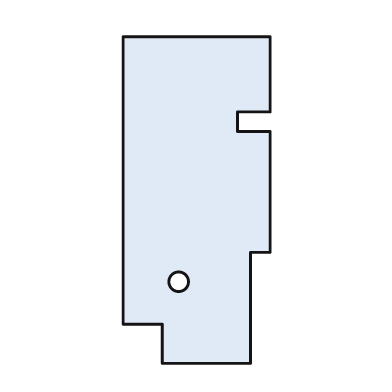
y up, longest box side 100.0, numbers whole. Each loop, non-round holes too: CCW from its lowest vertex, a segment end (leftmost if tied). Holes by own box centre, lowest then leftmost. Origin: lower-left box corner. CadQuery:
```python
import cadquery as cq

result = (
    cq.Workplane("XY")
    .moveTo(12.0, 0.0)
    .lineTo(39.0, 0.0)
    .lineTo(39.0, 34.0)
    .lineTo(45.0, 34.0)
    .lineTo(45.0, 71.0)
    .lineTo(35.0, 71.0)
    .lineTo(35.0, 77.0)
    .lineTo(45.0, 77.0)
    .lineTo(45.0, 100.0)
    .lineTo(0.0, 100.0)
    .lineTo(0.0, 12.0)
    .lineTo(12.0, 12.0)
    .close()
    .moveTo(17.0, 25.0)
    .circle(3.0)
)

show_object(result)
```